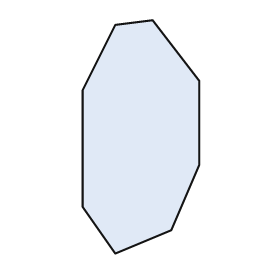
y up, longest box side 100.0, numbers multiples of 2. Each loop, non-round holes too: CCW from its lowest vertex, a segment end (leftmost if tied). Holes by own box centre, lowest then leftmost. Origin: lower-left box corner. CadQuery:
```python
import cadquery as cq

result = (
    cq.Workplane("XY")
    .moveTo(14.0, 0.0)
    .lineTo(38.0, 10.0)
    .lineTo(50.0, 38.0)
    .lineTo(50.0, 74.0)
    .lineTo(30.0, 100.0)
    .lineTo(14.0, 98.0)
    .lineTo(0.0, 70.0)
    .lineTo(0.0, 20.0)
    .close()
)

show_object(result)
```